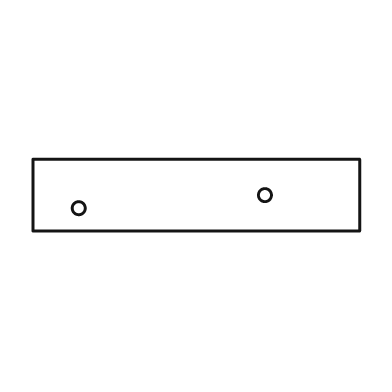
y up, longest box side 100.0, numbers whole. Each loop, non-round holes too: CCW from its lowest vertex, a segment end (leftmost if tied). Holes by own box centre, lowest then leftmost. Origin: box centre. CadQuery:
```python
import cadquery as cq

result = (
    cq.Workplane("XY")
    .moveTo(-50.0, -11.0)
    .lineTo(50.0, -11.0)
    .lineTo(50.0, 11.0)
    .lineTo(-50.0, 11.0)
    .close()
    .moveTo(-36.0, -4.0)
    .circle(2.0)
    .moveTo(21.0, 0.0)
    .circle(2.0)
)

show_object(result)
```